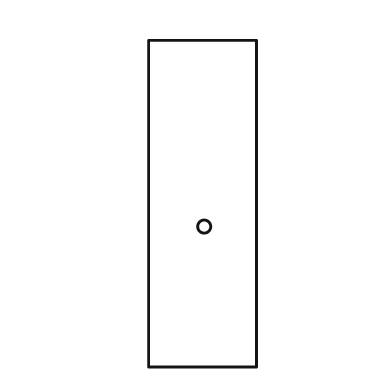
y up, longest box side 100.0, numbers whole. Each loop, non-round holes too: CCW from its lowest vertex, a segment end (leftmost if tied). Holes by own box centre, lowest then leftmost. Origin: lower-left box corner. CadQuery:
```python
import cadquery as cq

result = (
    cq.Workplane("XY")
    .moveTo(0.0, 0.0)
    .lineTo(33.0, 0.0)
    .lineTo(33.0, 100.0)
    .lineTo(0.0, 100.0)
    .close()
    .moveTo(17.0, 43.0)
    .circle(2.0)
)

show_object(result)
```